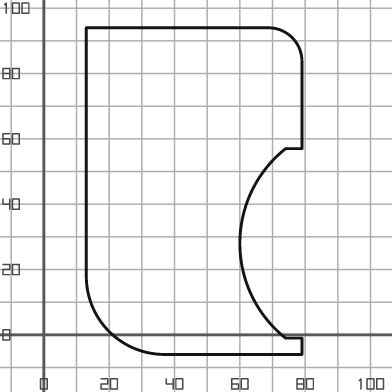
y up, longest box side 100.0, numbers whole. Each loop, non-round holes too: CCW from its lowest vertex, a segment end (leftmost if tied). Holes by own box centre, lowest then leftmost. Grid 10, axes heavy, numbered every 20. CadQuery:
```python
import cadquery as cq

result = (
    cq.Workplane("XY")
    .moveTo(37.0, -6.0)
    .lineTo(79.0, -6.0)
    .lineTo(79.0, -1.0)
    .lineTo(74.0, -1.0)
    .threePointArc((60.0, 28.0), (74.0, 57.0))
    .lineTo(79.0, 57.0)
    .lineTo(79.0, 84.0)
    .threePointArc((76.0, 91.0), (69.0, 94.0))
    .lineTo(13.0, 94.0)
    .lineTo(13.0, 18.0)
    .threePointArc((20.0, 1.0), (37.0, -6.0))
    .close()
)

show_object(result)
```